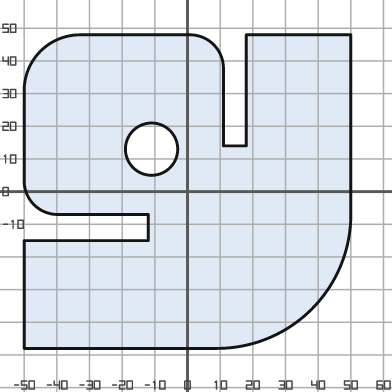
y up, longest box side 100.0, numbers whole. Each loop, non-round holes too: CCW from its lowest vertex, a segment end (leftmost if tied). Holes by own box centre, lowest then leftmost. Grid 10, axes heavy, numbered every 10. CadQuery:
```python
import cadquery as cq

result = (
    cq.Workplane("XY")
    .moveTo(-50.0, -48.0)
    .lineTo(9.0, -48.0)
    .threePointArc((38.0, -36.0), (50.0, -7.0))
    .lineTo(50.0, 48.0)
    .lineTo(18.0, 48.0)
    .lineTo(18.0, 14.0)
    .lineTo(11.0, 14.0)
    .lineTo(11.0, 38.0)
    .threePointArc((8.0, 45.0), (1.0, 48.0))
    .lineTo(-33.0, 48.0)
    .threePointArc((-45.0, 43.0), (-50.0, 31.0))
    .lineTo(-50.0, 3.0)
    .threePointArc((-47.0, -4.0), (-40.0, -7.0))
    .lineTo(-12.0, -7.0)
    .lineTo(-12.0, -15.0)
    .lineTo(-50.0, -15.0)
    .close()
    .moveTo(-11.0, 13.0)
    .circle(8.0)
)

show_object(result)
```